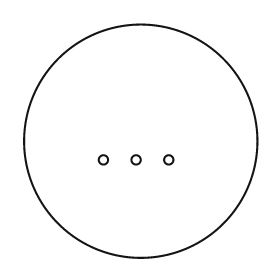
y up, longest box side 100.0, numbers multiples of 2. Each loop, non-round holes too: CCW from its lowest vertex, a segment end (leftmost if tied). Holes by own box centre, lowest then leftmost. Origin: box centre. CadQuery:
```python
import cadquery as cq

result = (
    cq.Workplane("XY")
    .moveTo(0.0, 0.0)
    .circle(50.0)
    .moveTo(-16.0, -8.0)
    .circle(2.0)
    .moveTo(-2.0, -8.0)
    .circle(2.0)
    .moveTo(12.0, -8.0)
    .circle(2.0)
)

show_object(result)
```